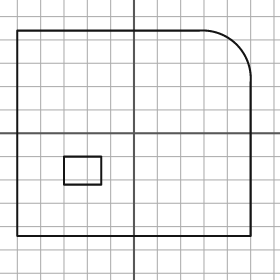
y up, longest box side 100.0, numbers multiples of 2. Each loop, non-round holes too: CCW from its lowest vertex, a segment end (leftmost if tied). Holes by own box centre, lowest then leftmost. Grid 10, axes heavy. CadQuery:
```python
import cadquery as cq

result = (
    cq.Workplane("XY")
    .moveTo(-50.0, -44.0)
    .lineTo(50.0, -44.0)
    .lineTo(50.0, 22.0)
    .threePointArc((44.0, 38.0), (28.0, 44.0))
    .lineTo(-50.0, 44.0)
    .close()
    .moveTo(-30.0, -22.0)
    .lineTo(-14.0, -22.0)
    .lineTo(-14.0, -10.0)
    .lineTo(-30.0, -10.0)
    .close()
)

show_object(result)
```